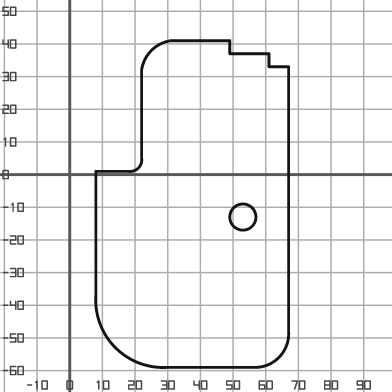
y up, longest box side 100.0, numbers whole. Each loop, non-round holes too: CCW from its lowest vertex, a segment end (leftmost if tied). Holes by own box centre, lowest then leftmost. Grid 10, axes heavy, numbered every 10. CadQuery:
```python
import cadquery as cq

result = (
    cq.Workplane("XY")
    .moveTo(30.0, -59.0)
    .lineTo(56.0, -59.0)
    .threePointArc((64.0, -56.0), (67.0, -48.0))
    .lineTo(67.0, 33.0)
    .lineTo(61.0, 33.0)
    .lineTo(61.0, 37.0)
    .lineTo(49.0, 37.0)
    .lineTo(49.0, 41.0)
    .lineTo(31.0, 41.0)
    .threePointArc((25.0, 38.0), (22.0, 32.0))
    .lineTo(22.0, 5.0)
    .threePointArc((21.0, 2.0), (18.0, 1.0))
    .lineTo(8.0, 1.0)
    .lineTo(8.0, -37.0)
    .threePointArc((14.0, -53.0), (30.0, -59.0))
    .close()
    .moveTo(53.0, -13.0)
    .circle(4.0)
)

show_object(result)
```